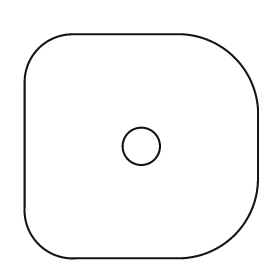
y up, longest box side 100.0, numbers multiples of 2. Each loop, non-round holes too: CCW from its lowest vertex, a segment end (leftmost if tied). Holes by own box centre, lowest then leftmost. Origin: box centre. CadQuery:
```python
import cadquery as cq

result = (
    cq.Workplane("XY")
    .moveTo(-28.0, -48.0)
    .lineTo(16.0, -48.0)
    .threePointArc((40.0, -38.0), (50.0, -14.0))
    .lineTo(50.0, 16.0)
    .threePointArc((40.0, 38.0), (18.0, 48.0))
    .lineTo(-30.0, 48.0)
    .threePointArc((-44.0, 42.0), (-50.0, 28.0))
    .lineTo(-50.0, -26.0)
    .threePointArc((-44.0, -42.0), (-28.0, -48.0))
    .close()
    .moveTo(0.0, 0.0)
    .circle(8.0)
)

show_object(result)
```